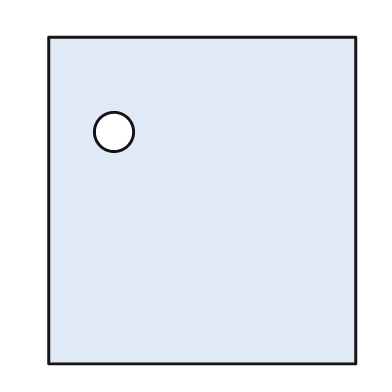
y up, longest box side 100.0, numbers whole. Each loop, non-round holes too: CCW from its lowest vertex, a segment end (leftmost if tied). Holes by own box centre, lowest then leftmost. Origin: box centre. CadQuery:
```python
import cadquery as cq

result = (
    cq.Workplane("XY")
    .moveTo(-47.0, -50.0)
    .lineTo(47.0, -50.0)
    .lineTo(47.0, 50.0)
    .lineTo(-47.0, 50.0)
    .close()
    .moveTo(-27.0, 21.0)
    .circle(6.0)
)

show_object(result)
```